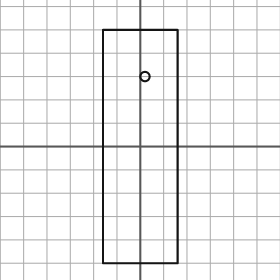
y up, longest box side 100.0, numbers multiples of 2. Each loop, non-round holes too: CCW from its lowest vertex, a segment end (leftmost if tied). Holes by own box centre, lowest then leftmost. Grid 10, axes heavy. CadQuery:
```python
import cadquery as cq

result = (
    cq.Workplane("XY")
    .moveTo(-16.0, -50.0)
    .lineTo(16.0, -50.0)
    .lineTo(16.0, 50.0)
    .lineTo(-16.0, 50.0)
    .close()
    .moveTo(2.0, 30.0)
    .circle(2.0)
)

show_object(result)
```